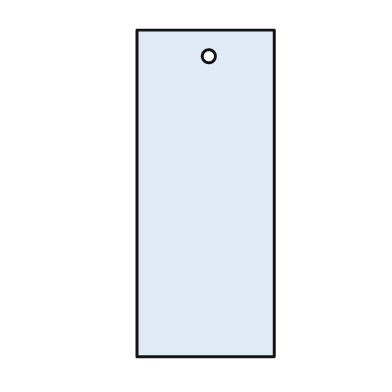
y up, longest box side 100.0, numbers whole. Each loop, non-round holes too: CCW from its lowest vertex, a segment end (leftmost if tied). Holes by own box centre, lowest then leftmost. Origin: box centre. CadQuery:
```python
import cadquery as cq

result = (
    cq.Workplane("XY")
    .moveTo(-21.0, -50.0)
    .lineTo(21.0, -50.0)
    .lineTo(21.0, 50.0)
    .lineTo(-21.0, 50.0)
    .close()
    .moveTo(1.0, 42.0)
    .circle(2.0)
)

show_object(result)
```